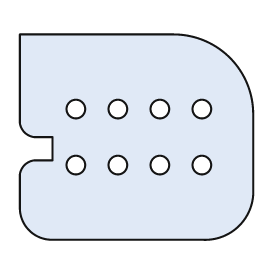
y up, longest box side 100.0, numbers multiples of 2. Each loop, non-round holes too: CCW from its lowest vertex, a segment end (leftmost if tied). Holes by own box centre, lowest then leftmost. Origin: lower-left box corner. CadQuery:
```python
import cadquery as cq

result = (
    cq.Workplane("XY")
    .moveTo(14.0, 0.0)
    .lineTo(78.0, 0.0)
    .threePointArc((94.0, 6.0), (100.0, 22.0))
    .lineTo(100.0, 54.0)
    .threePointArc((90.0, 78.0), (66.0, 88.0))
    .lineTo(0.0, 88.0)
    .lineTo(0.0, 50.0)
    .threePointArc((2.0, 46.0), (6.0, 44.0))
    .lineTo(14.0, 44.0)
    .lineTo(14.0, 34.0)
    .lineTo(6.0, 34.0)
    .threePointArc((2.0, 32.0), (0.0, 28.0))
    .lineTo(0.0, 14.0)
    .threePointArc((4.0, 4.0), (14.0, 0.0))
    .close()
    .moveTo(24.0, 32.0)
    .circle(4.0)
    .moveTo(42.0, 32.0)
    .circle(4.0)
    .moveTo(60.0, 32.0)
    .circle(4.0)
    .moveTo(78.0, 32.0)
    .circle(4.0)
    .moveTo(24.0, 56.0)
    .circle(4.0)
    .moveTo(42.0, 56.0)
    .circle(4.0)
    .moveTo(60.0, 56.0)
    .circle(4.0)
    .moveTo(78.0, 56.0)
    .circle(4.0)
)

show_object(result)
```